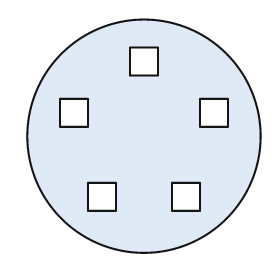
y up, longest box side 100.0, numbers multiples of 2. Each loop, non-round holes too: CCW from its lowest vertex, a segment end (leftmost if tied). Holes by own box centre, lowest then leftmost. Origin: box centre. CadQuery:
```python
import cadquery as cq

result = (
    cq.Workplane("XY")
    .moveTo(0.0, 0.0)
    .circle(50.0)
    .moveTo(-24.0, -32.0)
    .lineTo(-12.0, -32.0)
    .lineTo(-12.0, -20.0)
    .lineTo(-24.0, -20.0)
    .close()
    .moveTo(12.0, -32.0)
    .lineTo(24.0, -32.0)
    .lineTo(24.0, -20.0)
    .lineTo(12.0, -20.0)
    .close()
    .moveTo(-36.0, 4.0)
    .lineTo(-24.0, 4.0)
    .lineTo(-24.0, 16.0)
    .lineTo(-36.0, 16.0)
    .close()
    .moveTo(24.0, 4.0)
    .lineTo(36.0, 4.0)
    .lineTo(36.0, 16.0)
    .lineTo(24.0, 16.0)
    .close()
    .moveTo(-6.0, 26.0)
    .lineTo(6.0, 26.0)
    .lineTo(6.0, 38.0)
    .lineTo(-6.0, 38.0)
    .close()
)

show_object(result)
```